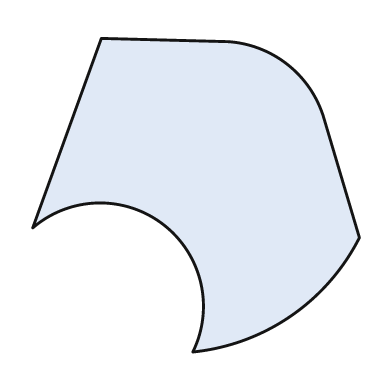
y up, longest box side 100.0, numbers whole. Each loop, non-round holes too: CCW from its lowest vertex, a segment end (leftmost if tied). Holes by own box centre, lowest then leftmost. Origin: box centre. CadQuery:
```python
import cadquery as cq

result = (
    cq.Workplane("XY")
    .moveTo(-1.0, -48.0)
    .threePointArc((29.0, -37.0), (50.0, -13.0))
    .lineTo(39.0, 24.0)
    .threePointArc((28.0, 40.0), (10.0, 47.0))
    .lineTo(-29.0, 48.0)
    .lineTo(-50.0, -10.0)
    .threePointArc((-10.0, -9.0), (-1.0, -48.0))
    .close()
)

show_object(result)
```